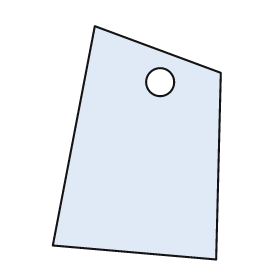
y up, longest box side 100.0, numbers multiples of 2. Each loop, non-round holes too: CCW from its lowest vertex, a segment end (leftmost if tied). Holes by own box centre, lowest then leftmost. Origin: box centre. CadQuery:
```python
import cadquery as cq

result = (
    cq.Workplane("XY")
    .moveTo(34.0, -50.0)
    .lineTo(36.0, 30.0)
    .lineTo(-18.0, 50.0)
    .lineTo(-36.0, -44.0)
    .close()
    .moveTo(10.0, 26.0)
    .circle(6.0)
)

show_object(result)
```